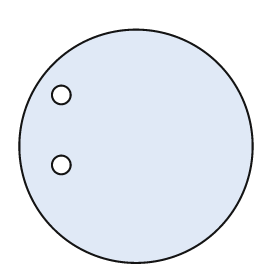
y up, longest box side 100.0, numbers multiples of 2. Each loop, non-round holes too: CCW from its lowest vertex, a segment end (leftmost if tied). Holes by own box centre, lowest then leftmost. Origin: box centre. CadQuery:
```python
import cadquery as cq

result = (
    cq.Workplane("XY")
    .moveTo(0.0, 0.0)
    .circle(50.0)
    .moveTo(-32.0, -8.0)
    .circle(4.0)
    .moveTo(-32.0, 22.0)
    .circle(4.0)
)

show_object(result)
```